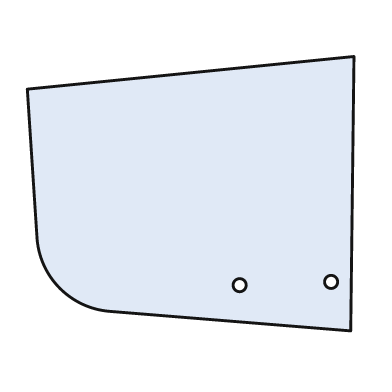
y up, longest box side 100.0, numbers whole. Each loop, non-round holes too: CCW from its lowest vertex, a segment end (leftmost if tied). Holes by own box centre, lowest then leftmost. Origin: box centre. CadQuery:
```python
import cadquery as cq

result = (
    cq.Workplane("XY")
    .moveTo(49.0, -42.0)
    .lineTo(50.0, 42.0)
    .lineTo(-50.0, 32.0)
    .lineTo(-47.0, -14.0)
    .threePointArc((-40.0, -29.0), (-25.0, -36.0))
    .close()
    .moveTo(15.0, -28.0)
    .circle(2.0)
    .moveTo(43.0, -27.0)
    .circle(2.0)
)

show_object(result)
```